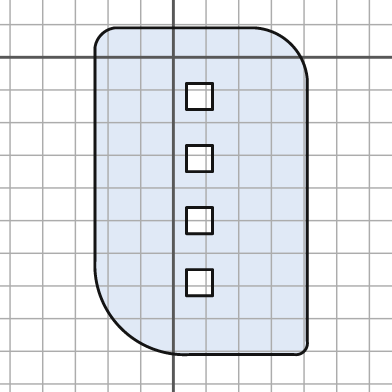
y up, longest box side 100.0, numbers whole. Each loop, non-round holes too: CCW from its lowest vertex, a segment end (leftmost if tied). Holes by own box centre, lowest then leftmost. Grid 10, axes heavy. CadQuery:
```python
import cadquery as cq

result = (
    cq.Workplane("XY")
    .moveTo(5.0, -91.0)
    .lineTo(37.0, -91.0)
    .threePointArc((40.0, -90.0), (41.0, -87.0))
    .lineTo(41.0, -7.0)
    .threePointArc((36.0, 4.0), (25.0, 9.0))
    .lineTo(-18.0, 9.0)
    .threePointArc((-22.0, 7.0), (-24.0, 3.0))
    .lineTo(-24.0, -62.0)
    .threePointArc((-16.0, -83.0), (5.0, -91.0))
    .close()
    .moveTo(4.0, -73.0)
    .lineTo(12.0, -73.0)
    .lineTo(12.0, -65.0)
    .lineTo(4.0, -65.0)
    .close()
    .moveTo(4.0, -54.0)
    .lineTo(12.0, -54.0)
    .lineTo(12.0, -46.0)
    .lineTo(4.0, -46.0)
    .close()
    .moveTo(4.0, -35.0)
    .lineTo(12.0, -35.0)
    .lineTo(12.0, -27.0)
    .lineTo(4.0, -27.0)
    .close()
    .moveTo(4.0, -16.0)
    .lineTo(12.0, -16.0)
    .lineTo(12.0, -8.0)
    .lineTo(4.0, -8.0)
    .close()
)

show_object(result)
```